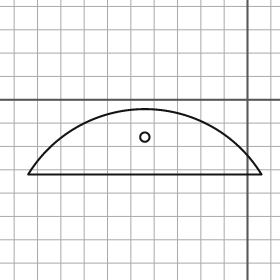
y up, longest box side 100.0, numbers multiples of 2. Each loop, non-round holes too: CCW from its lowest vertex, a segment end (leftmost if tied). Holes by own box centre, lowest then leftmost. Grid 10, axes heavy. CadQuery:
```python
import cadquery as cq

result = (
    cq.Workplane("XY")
    .moveTo(-94.0, -32.0)
    .lineTo(6.0, -32.0)
    .threePointArc((-44.0, -4.0), (-94.0, -32.0))
    .close()
    .moveTo(-44.0, -16.0)
    .circle(2.0)
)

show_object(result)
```